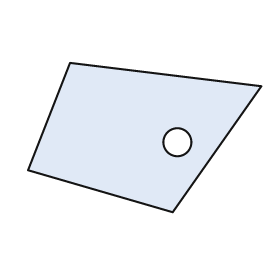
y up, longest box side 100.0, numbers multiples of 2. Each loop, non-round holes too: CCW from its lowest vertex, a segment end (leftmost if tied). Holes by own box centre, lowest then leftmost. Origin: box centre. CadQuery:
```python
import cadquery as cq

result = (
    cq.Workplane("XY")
    .moveTo(12.0, -32.0)
    .lineTo(50.0, 22.0)
    .lineTo(-32.0, 32.0)
    .lineTo(-50.0, -14.0)
    .close()
    .moveTo(14.0, -2.0)
    .circle(6.0)
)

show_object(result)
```